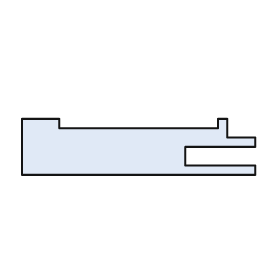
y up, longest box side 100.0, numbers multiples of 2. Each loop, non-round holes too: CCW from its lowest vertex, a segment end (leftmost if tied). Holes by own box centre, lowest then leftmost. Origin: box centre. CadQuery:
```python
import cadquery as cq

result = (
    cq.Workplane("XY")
    .moveTo(-50.0, -12.0)
    .lineTo(50.0, -12.0)
    .lineTo(50.0, -8.0)
    .lineTo(20.0, -8.0)
    .lineTo(20.0, 0.0)
    .lineTo(50.0, 0.0)
    .lineTo(50.0, 4.0)
    .lineTo(38.0, 4.0)
    .lineTo(38.0, 12.0)
    .lineTo(34.0, 12.0)
    .lineTo(34.0, 8.0)
    .lineTo(-34.0, 8.0)
    .lineTo(-34.0, 12.0)
    .lineTo(-50.0, 12.0)
    .close()
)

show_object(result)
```